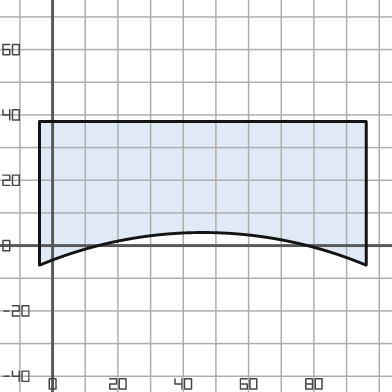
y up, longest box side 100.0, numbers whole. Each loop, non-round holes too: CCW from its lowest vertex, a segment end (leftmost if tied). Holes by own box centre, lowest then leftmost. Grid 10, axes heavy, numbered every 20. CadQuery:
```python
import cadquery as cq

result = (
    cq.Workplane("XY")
    .moveTo(-4.0, -6.0)
    .threePointArc((46.0, 4.0), (96.0, -6.0))
    .lineTo(96.0, 38.0)
    .lineTo(-4.0, 38.0)
    .close()
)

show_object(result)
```